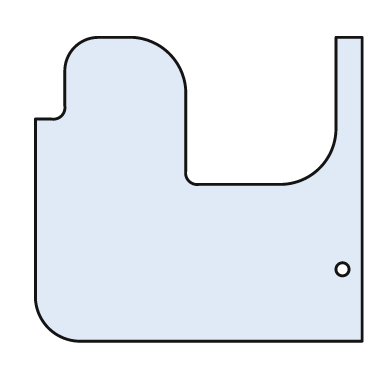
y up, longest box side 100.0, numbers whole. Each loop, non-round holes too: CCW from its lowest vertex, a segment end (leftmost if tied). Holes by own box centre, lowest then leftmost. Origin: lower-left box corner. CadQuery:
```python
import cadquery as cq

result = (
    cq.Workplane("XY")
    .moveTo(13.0, 0.0)
    .lineTo(100.0, 0.0)
    .lineTo(100.0, 93.0)
    .lineTo(92.0, 93.0)
    .lineTo(92.0, 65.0)
    .threePointArc((87.0, 53.0), (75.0, 48.0))
    .lineTo(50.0, 48.0)
    .threePointArc((47.0, 49.0), (46.0, 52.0))
    .lineTo(46.0, 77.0)
    .threePointArc((41.0, 88.0), (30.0, 93.0))
    .lineTo(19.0, 93.0)
    .threePointArc((12.0, 90.0), (9.0, 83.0))
    .lineTo(9.0, 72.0)
    .threePointArc((8.0, 69.0), (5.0, 68.0))
    .lineTo(0.0, 68.0)
    .lineTo(0.0, 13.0)
    .threePointArc((4.0, 4.0), (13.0, 0.0))
    .close()
    .moveTo(94.0, 22.0)
    .circle(2.0)
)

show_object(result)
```